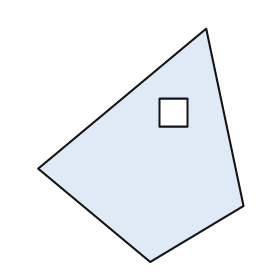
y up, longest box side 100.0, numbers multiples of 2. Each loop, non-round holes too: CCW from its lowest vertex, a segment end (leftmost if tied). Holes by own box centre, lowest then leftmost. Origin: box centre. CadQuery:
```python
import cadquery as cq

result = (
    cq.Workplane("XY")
    .moveTo(4.0, -50.0)
    .lineTo(44.0, -26.0)
    .lineTo(28.0, 50.0)
    .lineTo(-44.0, -10.0)
    .close()
    .moveTo(8.0, 8.0)
    .lineTo(20.0, 8.0)
    .lineTo(20.0, 20.0)
    .lineTo(8.0, 20.0)
    .close()
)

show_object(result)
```